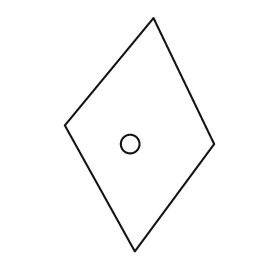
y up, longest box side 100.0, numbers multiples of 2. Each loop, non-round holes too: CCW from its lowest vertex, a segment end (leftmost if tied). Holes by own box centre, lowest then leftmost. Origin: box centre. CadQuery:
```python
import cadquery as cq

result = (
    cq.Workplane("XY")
    .moveTo(-2.0, -50.0)
    .lineTo(32.0, -4.0)
    .lineTo(6.0, 50.0)
    .lineTo(-32.0, 4.0)
    .close()
    .moveTo(-4.0, -4.0)
    .circle(4.0)
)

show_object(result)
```